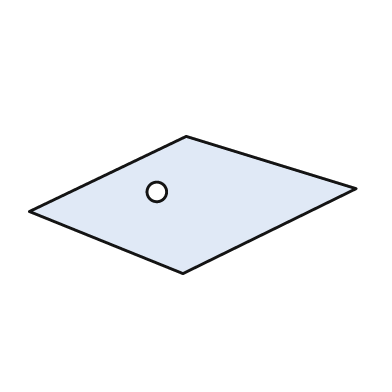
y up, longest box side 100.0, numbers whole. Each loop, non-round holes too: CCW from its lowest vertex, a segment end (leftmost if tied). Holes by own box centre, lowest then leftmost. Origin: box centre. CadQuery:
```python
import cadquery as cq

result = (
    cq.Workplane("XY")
    .moveTo(-3.0, -21.0)
    .lineTo(50.0, 5.0)
    .lineTo(-2.0, 21.0)
    .lineTo(-50.0, -2.0)
    .close()
    .moveTo(-11.0, 4.0)
    .circle(3.0)
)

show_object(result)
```